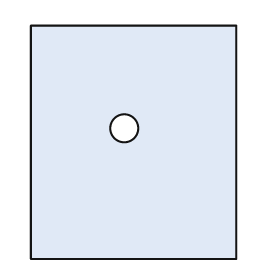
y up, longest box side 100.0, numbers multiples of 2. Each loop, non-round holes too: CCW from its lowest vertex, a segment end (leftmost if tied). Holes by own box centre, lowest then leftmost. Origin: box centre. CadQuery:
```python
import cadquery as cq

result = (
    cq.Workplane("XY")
    .moveTo(-44.0, -50.0)
    .lineTo(44.0, -50.0)
    .lineTo(44.0, 50.0)
    .lineTo(-44.0, 50.0)
    .close()
    .moveTo(-4.0, 6.0)
    .circle(6.0)
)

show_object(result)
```